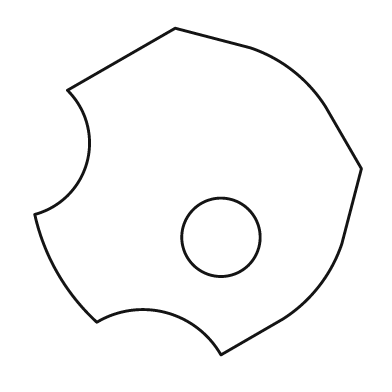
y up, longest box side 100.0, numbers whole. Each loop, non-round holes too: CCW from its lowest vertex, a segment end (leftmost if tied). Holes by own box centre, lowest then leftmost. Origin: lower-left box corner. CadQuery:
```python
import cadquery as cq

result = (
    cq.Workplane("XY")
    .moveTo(57.0, 0.0)
    .lineTo(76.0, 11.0)
    .threePointArc((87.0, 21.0), (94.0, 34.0))
    .lineTo(100.0, 57.0)
    .lineTo(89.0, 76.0)
    .threePointArc((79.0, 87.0), (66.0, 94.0))
    .lineTo(43.0, 100.0)
    .lineTo(10.0, 81.0)
    .threePointArc((16.0, 59.0), (0.0, 43.0))
    .threePointArc((7.0, 25.0), (19.0, 10.0))
    .threePointArc((40.0, 13.0), (57.0, 0.0))
    .close()
    .moveTo(57.0, 36.0)
    .circle(12.0)
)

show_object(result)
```